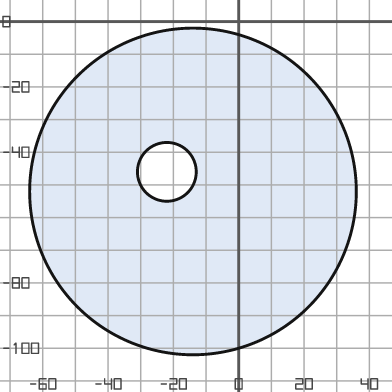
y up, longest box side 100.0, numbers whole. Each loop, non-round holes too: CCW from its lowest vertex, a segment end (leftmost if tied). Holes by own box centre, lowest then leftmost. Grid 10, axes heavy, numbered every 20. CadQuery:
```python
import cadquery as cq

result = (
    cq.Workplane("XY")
    .moveTo(-14.0, -52.0)
    .circle(50.0)
    .moveTo(-22.0, -46.0)
    .circle(9.0)
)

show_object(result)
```